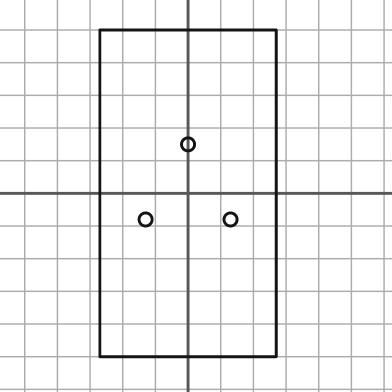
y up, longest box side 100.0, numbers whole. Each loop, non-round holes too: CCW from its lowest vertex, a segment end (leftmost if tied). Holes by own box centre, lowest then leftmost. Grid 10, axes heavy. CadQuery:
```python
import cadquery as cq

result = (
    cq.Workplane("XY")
    .moveTo(-27.0, -50.0)
    .lineTo(27.0, -50.0)
    .lineTo(27.0, 50.0)
    .lineTo(-27.0, 50.0)
    .close()
    .moveTo(-13.0, -8.0)
    .circle(2.0)
    .moveTo(13.0, -8.0)
    .circle(2.0)
    .moveTo(0.0, 15.0)
    .circle(2.0)
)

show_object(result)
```